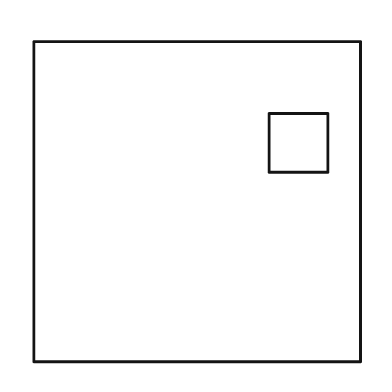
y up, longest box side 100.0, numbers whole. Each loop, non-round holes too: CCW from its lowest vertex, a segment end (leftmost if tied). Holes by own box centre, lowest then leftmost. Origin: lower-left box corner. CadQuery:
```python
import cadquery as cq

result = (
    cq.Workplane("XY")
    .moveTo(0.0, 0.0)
    .lineTo(100.0, 0.0)
    .lineTo(100.0, 98.0)
    .lineTo(0.0, 98.0)
    .close()
    .moveTo(72.0, 58.0)
    .lineTo(90.0, 58.0)
    .lineTo(90.0, 76.0)
    .lineTo(72.0, 76.0)
    .close()
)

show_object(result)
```